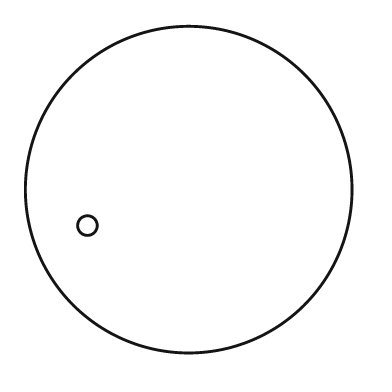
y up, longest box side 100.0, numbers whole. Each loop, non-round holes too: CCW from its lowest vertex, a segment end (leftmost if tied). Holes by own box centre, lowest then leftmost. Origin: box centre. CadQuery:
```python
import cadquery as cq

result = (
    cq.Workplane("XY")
    .moveTo(0.0, 0.0)
    .circle(50.0)
    .moveTo(-31.0, -11.0)
    .circle(3.0)
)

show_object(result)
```